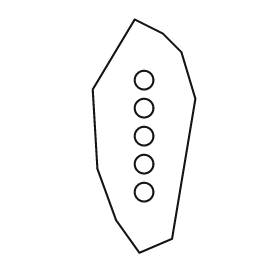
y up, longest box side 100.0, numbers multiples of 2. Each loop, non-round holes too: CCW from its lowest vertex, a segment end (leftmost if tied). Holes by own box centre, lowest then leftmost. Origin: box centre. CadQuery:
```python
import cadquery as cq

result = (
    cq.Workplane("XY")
    .moveTo(-2.0, -50.0)
    .lineTo(12.0, -44.0)
    .lineTo(22.0, 16.0)
    .lineTo(16.0, 36.0)
    .lineTo(8.0, 44.0)
    .lineTo(-4.0, 50.0)
    .lineTo(-22.0, 20.0)
    .lineTo(-20.0, -14.0)
    .lineTo(-12.0, -36.0)
    .close()
    .moveTo(0.0, -24.0)
    .circle(4.0)
    .moveTo(0.0, -12.0)
    .circle(4.0)
    .moveTo(0.0, 0.0)
    .circle(4.0)
    .moveTo(0.0, 12.0)
    .circle(4.0)
    .moveTo(0.0, 24.0)
    .circle(4.0)
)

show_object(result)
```